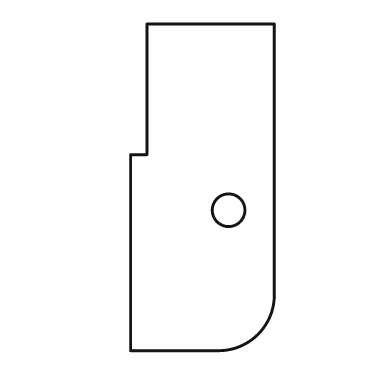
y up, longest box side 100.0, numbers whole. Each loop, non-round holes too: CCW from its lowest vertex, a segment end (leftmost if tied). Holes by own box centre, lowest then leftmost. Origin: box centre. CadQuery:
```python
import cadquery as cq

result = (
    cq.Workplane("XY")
    .moveTo(-22.0, -50.0)
    .lineTo(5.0, -50.0)
    .threePointArc((17.0, -45.0), (22.0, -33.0))
    .lineTo(22.0, 50.0)
    .lineTo(-17.0, 50.0)
    .lineTo(-17.0, 10.0)
    .lineTo(-22.0, 10.0)
    .close()
    .moveTo(8.0, -7.0)
    .circle(5.0)
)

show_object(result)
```